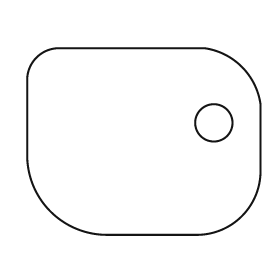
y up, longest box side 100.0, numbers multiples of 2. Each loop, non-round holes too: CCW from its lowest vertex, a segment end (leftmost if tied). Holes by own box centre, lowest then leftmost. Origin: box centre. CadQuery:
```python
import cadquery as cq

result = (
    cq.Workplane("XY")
    .moveTo(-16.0, -40.0)
    .lineTo(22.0, -40.0)
    .threePointArc((42.0, -32.0), (50.0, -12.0))
    .lineTo(50.0, 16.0)
    .threePointArc((42.0, 32.0), (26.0, 40.0))
    .lineTo(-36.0, 40.0)
    .threePointArc((-46.0, 36.0), (-50.0, 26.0))
    .lineTo(-50.0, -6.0)
    .threePointArc((-40.0, -30.0), (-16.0, -40.0))
    .close()
    .moveTo(30.0, 8.0)
    .circle(8.0)
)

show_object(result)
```